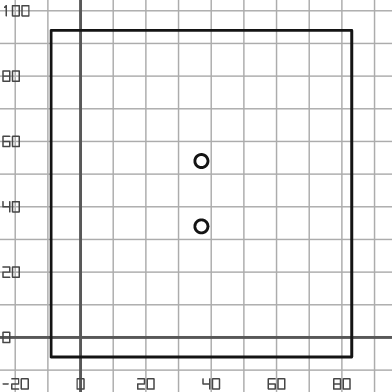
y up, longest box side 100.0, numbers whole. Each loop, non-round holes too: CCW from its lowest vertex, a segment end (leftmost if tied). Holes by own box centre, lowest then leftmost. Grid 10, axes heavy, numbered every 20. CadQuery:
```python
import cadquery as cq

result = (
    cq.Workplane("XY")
    .moveTo(-9.0, -6.0)
    .lineTo(83.0, -6.0)
    .lineTo(83.0, 94.0)
    .lineTo(-9.0, 94.0)
    .close()
    .moveTo(37.0, 34.0)
    .circle(2.0)
    .moveTo(37.0, 54.0)
    .circle(2.0)
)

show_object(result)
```